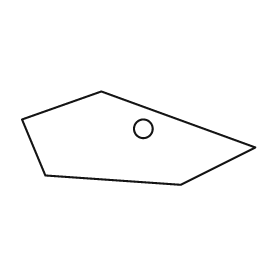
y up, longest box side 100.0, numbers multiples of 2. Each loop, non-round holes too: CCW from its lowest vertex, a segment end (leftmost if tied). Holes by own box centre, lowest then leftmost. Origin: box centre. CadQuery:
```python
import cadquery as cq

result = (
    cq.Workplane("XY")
    .moveTo(18.0, -20.0)
    .lineTo(50.0, -4.0)
    .lineTo(-16.0, 20.0)
    .lineTo(-50.0, 8.0)
    .lineTo(-40.0, -16.0)
    .close()
    .moveTo(2.0, 4.0)
    .circle(4.0)
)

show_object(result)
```